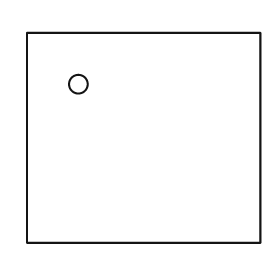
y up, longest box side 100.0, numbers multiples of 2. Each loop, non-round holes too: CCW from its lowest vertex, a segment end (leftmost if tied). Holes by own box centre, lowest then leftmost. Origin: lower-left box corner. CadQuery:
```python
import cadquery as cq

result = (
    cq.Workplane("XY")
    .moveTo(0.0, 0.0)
    .lineTo(100.0, 0.0)
    .lineTo(100.0, 90.0)
    .lineTo(0.0, 90.0)
    .close()
    .moveTo(22.0, 68.0)
    .circle(4.0)
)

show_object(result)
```